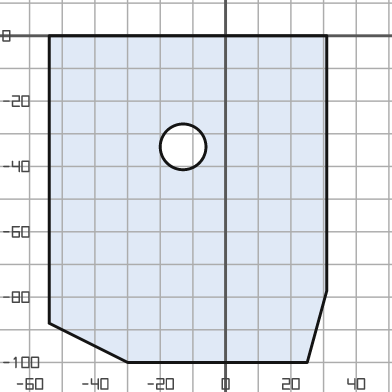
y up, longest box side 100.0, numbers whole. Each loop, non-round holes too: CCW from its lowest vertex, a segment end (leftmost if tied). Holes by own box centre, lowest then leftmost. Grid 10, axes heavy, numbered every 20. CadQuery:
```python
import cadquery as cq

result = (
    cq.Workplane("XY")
    .moveTo(-30.0, -100.0)
    .lineTo(25.0, -100.0)
    .lineTo(31.0, -78.0)
    .lineTo(31.0, 0.0)
    .lineTo(-54.0, 0.0)
    .lineTo(-54.0, -88.0)
    .close()
    .moveTo(-13.0, -34.0)
    .circle(7.0)
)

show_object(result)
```